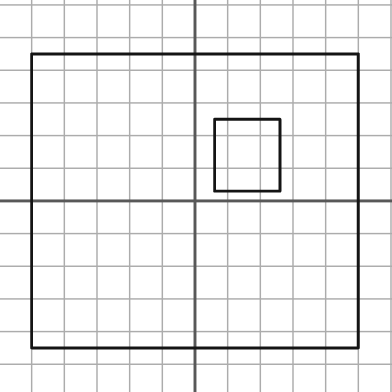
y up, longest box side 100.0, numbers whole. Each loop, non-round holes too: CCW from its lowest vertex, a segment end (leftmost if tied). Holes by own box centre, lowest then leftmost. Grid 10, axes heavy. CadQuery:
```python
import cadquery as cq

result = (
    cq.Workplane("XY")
    .moveTo(-50.0, -45.0)
    .lineTo(50.0, -45.0)
    .lineTo(50.0, 45.0)
    .lineTo(-50.0, 45.0)
    .close()
    .moveTo(6.0, 3.0)
    .lineTo(26.0, 3.0)
    .lineTo(26.0, 25.0)
    .lineTo(6.0, 25.0)
    .close()
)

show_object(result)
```